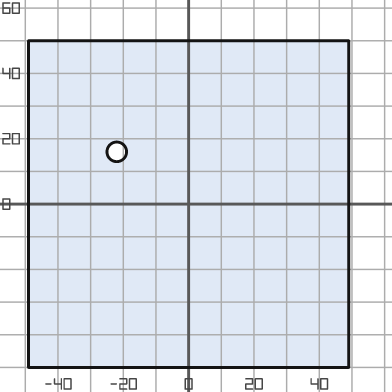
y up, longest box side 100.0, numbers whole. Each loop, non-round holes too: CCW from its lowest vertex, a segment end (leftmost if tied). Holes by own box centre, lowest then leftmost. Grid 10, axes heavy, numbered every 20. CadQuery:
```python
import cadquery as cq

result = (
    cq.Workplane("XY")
    .moveTo(-49.0, -50.0)
    .lineTo(49.0, -50.0)
    .lineTo(49.0, 50.0)
    .lineTo(-49.0, 50.0)
    .close()
    .moveTo(-22.0, 16.0)
    .circle(3.0)
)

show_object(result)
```